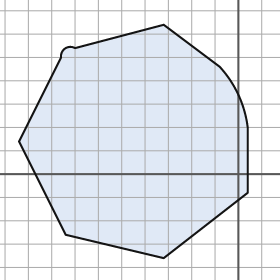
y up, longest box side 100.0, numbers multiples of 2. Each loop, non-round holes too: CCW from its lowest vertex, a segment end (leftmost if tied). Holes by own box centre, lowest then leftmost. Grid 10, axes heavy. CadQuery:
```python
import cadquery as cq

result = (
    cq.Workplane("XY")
    .moveTo(-32.0, -36.0)
    .lineTo(4.0, -8.0)
    .lineTo(4.0, 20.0)
    .threePointArc((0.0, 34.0), (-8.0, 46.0))
    .lineTo(-32.0, 64.0)
    .lineTo(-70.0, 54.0)
    .threePointArc((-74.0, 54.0), (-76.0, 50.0))
    .lineTo(-94.0, 14.0)
    .lineTo(-74.0, -26.0)
    .close()
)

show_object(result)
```